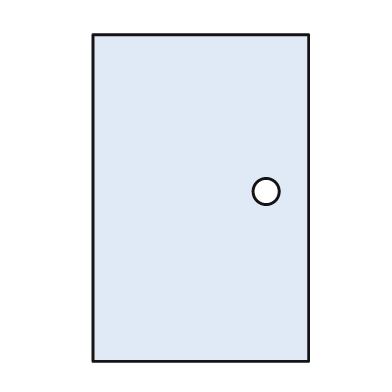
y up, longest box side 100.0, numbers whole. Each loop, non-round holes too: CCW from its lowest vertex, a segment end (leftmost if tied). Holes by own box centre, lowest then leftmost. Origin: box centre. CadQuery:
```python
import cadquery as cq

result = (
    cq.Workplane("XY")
    .moveTo(-33.0, -50.0)
    .lineTo(33.0, -50.0)
    .lineTo(33.0, 50.0)
    .lineTo(-33.0, 50.0)
    .close()
    .moveTo(20.0, 2.0)
    .circle(4.0)
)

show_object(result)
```